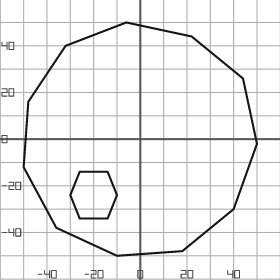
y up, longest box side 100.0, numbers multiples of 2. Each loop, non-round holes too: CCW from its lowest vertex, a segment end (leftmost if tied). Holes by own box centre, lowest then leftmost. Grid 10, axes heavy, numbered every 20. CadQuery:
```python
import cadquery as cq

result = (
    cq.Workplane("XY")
    .moveTo(-10.0, -50.0)
    .lineTo(18.0, -48.0)
    .lineTo(40.0, -30.0)
    .lineTo(50.0, -2.0)
    .lineTo(44.0, 26.0)
    .lineTo(22.0, 44.0)
    .lineTo(-6.0, 50.0)
    .lineTo(-32.0, 40.0)
    .lineTo(-48.0, 16.0)
    .lineTo(-50.0, -12.0)
    .lineTo(-36.0, -38.0)
    .close()
    .moveTo(-26.0, -34.0)
    .lineTo(-14.0, -34.0)
    .lineTo(-10.0, -24.0)
    .lineTo(-14.0, -14.0)
    .lineTo(-26.0, -14.0)
    .lineTo(-30.0, -24.0)
    .close()
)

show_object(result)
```